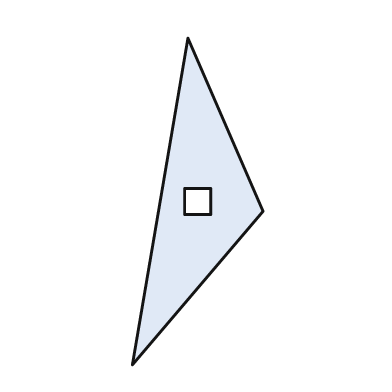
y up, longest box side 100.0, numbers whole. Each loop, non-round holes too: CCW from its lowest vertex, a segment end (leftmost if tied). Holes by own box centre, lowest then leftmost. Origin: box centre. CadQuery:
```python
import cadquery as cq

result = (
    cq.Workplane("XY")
    .moveTo(-20.0, -50.0)
    .lineTo(20.0, -3.0)
    .lineTo(-3.0, 50.0)
    .close()
    .moveTo(-4.0, -4.0)
    .lineTo(4.0, -4.0)
    .lineTo(4.0, 4.0)
    .lineTo(-4.0, 4.0)
    .close()
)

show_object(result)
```